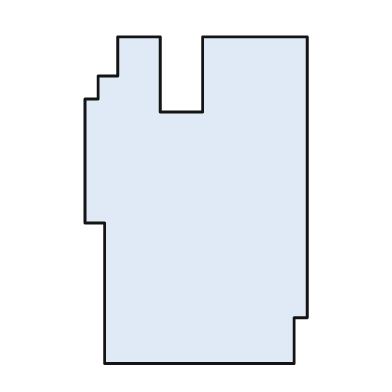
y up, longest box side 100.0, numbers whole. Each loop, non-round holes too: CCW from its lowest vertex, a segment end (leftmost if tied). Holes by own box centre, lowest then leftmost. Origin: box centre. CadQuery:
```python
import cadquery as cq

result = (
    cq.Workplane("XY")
    .moveTo(-28.0, -50.0)
    .lineTo(30.0, -50.0)
    .lineTo(30.0, -36.0)
    .lineTo(34.0, -36.0)
    .lineTo(34.0, 50.0)
    .lineTo(2.0, 50.0)
    .lineTo(2.0, 27.0)
    .lineTo(-11.0, 27.0)
    .lineTo(-11.0, 50.0)
    .lineTo(-24.0, 50.0)
    .lineTo(-24.0, 38.0)
    .lineTo(-30.0, 38.0)
    .lineTo(-30.0, 31.0)
    .lineTo(-34.0, 31.0)
    .lineTo(-34.0, -7.0)
    .lineTo(-28.0, -7.0)
    .close()
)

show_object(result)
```